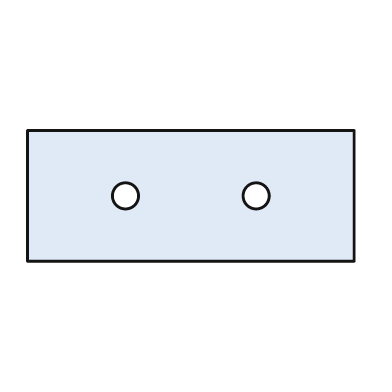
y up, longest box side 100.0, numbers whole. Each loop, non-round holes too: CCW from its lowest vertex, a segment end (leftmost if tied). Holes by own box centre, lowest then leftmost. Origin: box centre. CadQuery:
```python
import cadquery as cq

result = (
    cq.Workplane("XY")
    .moveTo(-50.0, -20.0)
    .lineTo(50.0, -20.0)
    .lineTo(50.0, 20.0)
    .lineTo(-50.0, 20.0)
    .close()
    .moveTo(-20.0, 0.0)
    .circle(4.0)
    .moveTo(20.0, 0.0)
    .circle(4.0)
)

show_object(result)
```